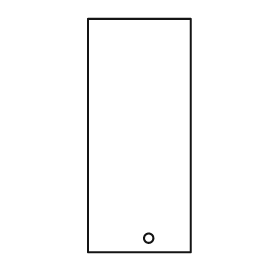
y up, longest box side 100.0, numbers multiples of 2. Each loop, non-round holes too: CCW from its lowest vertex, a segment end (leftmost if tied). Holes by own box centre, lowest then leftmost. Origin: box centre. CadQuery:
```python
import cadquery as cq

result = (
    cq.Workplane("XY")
    .moveTo(-22.0, -50.0)
    .lineTo(22.0, -50.0)
    .lineTo(22.0, 50.0)
    .lineTo(-22.0, 50.0)
    .close()
    .moveTo(4.0, -44.0)
    .circle(2.0)
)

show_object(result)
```